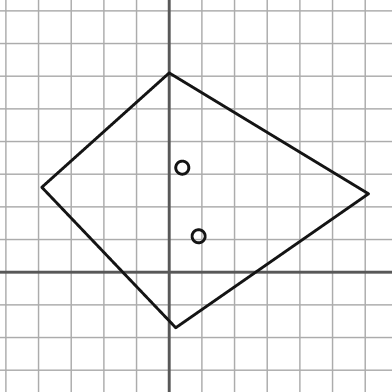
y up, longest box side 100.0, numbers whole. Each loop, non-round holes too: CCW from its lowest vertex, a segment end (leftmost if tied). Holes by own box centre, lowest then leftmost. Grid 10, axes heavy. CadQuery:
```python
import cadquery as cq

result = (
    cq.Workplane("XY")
    .moveTo(2.0, -17.0)
    .lineTo(61.0, 24.0)
    .lineTo(0.0, 61.0)
    .lineTo(-39.0, 26.0)
    .close()
    .moveTo(9.0, 11.0)
    .circle(2.0)
    .moveTo(4.0, 32.0)
    .circle(2.0)
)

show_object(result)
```